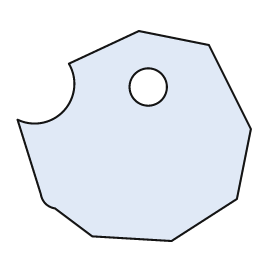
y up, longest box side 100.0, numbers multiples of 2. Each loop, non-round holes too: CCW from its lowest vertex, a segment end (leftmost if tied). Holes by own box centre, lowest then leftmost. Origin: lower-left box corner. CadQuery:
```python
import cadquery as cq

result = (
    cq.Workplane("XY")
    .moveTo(66.0, 0.0)
    .lineTo(94.0, 18.0)
    .lineTo(100.0, 48.0)
    .lineTo(82.0, 84.0)
    .lineTo(52.0, 90.0)
    .lineTo(22.0, 76.0)
    .threePointArc((20.0, 56.0), (0.0, 52.0))
    .lineTo(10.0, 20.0)
    .threePointArc((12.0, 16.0), (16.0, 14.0))
    .lineTo(32.0, 2.0)
    .close()
    .moveTo(56.0, 66.0)
    .circle(8.0)
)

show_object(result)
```